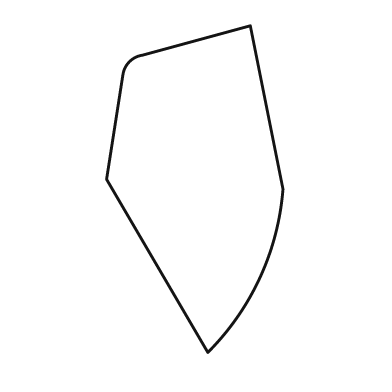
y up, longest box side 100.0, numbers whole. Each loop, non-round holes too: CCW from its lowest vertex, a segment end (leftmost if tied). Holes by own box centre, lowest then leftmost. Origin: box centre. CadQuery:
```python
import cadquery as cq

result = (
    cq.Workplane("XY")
    .moveTo(4.0, -50.0)
    .threePointArc((20.0, -27.0), (27.0, 0.0))
    .lineTo(17.0, 50.0)
    .lineTo(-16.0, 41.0)
    .threePointArc((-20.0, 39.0), (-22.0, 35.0))
    .lineTo(-27.0, 3.0)
    .close()
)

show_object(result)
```